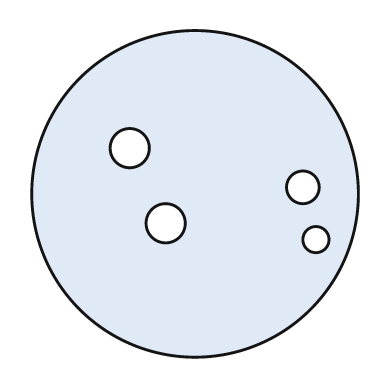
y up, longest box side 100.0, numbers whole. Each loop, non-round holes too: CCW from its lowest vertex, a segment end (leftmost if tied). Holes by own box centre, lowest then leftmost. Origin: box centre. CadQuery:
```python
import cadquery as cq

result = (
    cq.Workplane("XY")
    .moveTo(0.0, 0.0)
    .circle(50.0)
    .moveTo(37.0, -14.0)
    .circle(4.0)
    .moveTo(-9.0, -9.0)
    .circle(6.0)
    .moveTo(33.0, 2.0)
    .circle(5.0)
    .moveTo(-20.0, 14.0)
    .circle(6.0)
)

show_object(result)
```